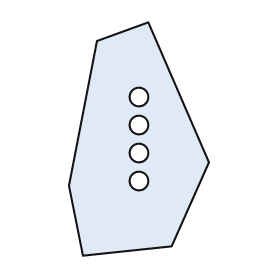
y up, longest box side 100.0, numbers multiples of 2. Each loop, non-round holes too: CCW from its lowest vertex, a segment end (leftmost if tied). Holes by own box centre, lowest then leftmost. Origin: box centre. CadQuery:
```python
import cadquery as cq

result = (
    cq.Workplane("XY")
    .moveTo(-24.0, -50.0)
    .lineTo(14.0, -46.0)
    .lineTo(30.0, -10.0)
    .lineTo(4.0, 50.0)
    .lineTo(-18.0, 42.0)
    .lineTo(-30.0, -20.0)
    .close()
    .moveTo(0.0, -18.0)
    .circle(4.0)
    .moveTo(0.0, -6.0)
    .circle(4.0)
    .moveTo(0.0, 6.0)
    .circle(4.0)
    .moveTo(0.0, 18.0)
    .circle(4.0)
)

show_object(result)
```